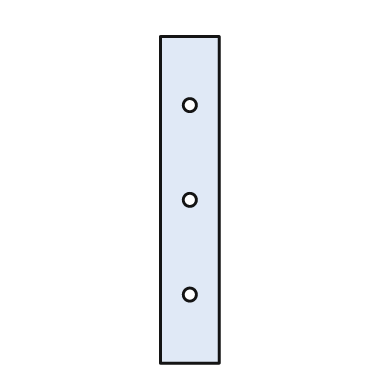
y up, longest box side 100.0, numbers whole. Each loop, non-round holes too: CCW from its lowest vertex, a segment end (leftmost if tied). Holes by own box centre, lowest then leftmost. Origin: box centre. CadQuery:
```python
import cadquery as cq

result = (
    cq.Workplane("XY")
    .moveTo(-9.0, -50.0)
    .lineTo(9.0, -50.0)
    .lineTo(9.0, 50.0)
    .lineTo(-9.0, 50.0)
    .close()
    .moveTo(0.0, -29.0)
    .circle(2.0)
    .moveTo(0.0, 0.0)
    .circle(2.0)
    .moveTo(0.0, 29.0)
    .circle(2.0)
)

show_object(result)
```